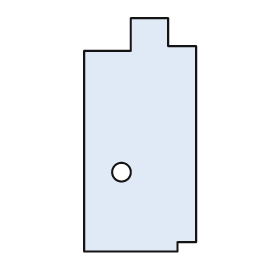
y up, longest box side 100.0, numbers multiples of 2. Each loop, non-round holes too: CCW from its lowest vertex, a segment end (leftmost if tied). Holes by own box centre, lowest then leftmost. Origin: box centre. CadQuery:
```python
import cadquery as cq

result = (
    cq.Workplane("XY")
    .moveTo(-24.0, -50.0)
    .lineTo(16.0, -50.0)
    .lineTo(16.0, -46.0)
    .lineTo(24.0, -46.0)
    .lineTo(24.0, 38.0)
    .lineTo(12.0, 38.0)
    .lineTo(12.0, 50.0)
    .lineTo(-4.0, 50.0)
    .lineTo(-4.0, 36.0)
    .lineTo(-24.0, 36.0)
    .close()
    .moveTo(-8.0, -16.0)
    .circle(4.0)
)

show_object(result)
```